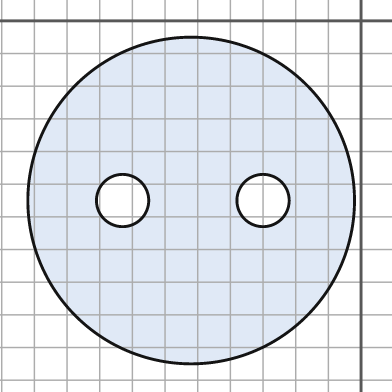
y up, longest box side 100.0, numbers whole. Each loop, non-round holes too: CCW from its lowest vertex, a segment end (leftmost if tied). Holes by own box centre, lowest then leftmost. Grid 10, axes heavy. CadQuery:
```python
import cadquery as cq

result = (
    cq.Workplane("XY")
    .moveTo(-52.0, -55.0)
    .circle(50.0)
    .moveTo(-73.0, -55.0)
    .circle(8.0)
    .moveTo(-30.0, -55.0)
    .circle(8.0)
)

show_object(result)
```